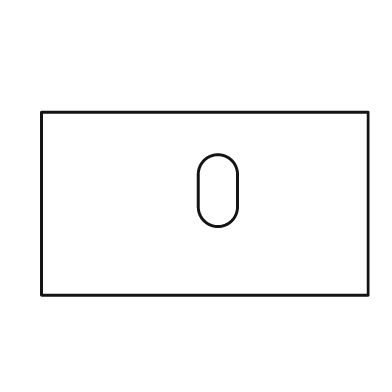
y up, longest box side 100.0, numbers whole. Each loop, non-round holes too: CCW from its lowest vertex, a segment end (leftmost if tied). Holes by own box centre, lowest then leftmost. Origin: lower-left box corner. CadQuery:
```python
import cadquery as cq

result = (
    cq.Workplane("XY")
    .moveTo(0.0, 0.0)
    .lineTo(100.0, 0.0)
    .lineTo(100.0, 56.0)
    .lineTo(0.0, 56.0)
    .close()
    .moveTo(48.0, 27.0)
    .threePointArc((54.0, 21.0), (60.0, 27.0))
    .lineTo(60.0, 37.0)
    .threePointArc((54.0, 43.0), (48.0, 37.0))
    .close()
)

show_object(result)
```